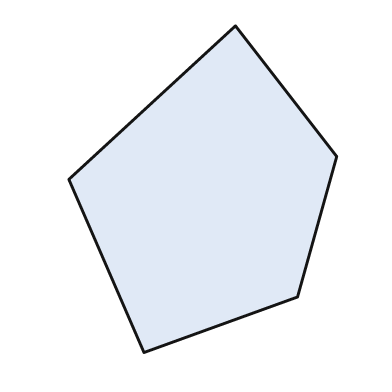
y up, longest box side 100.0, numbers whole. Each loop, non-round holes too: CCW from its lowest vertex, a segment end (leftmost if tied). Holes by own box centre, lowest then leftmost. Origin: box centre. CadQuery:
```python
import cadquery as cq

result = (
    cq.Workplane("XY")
    .moveTo(-18.0, -50.0)
    .lineTo(29.0, -33.0)
    .lineTo(41.0, 10.0)
    .lineTo(10.0, 50.0)
    .lineTo(-41.0, 3.0)
    .close()
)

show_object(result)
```